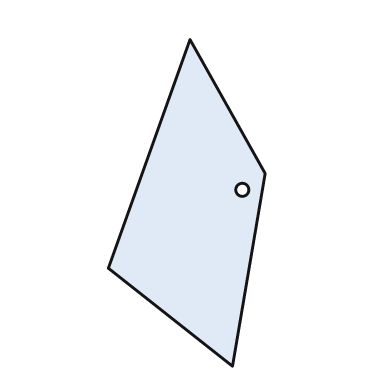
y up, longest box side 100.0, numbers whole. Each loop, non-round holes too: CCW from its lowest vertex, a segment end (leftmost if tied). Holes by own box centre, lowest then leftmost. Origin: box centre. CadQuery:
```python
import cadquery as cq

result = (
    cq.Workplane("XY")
    .moveTo(14.0, -50.0)
    .lineTo(24.0, 9.0)
    .lineTo(1.0, 50.0)
    .lineTo(-24.0, -20.0)
    .close()
    .moveTo(17.0, 4.0)
    .circle(2.0)
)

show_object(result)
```